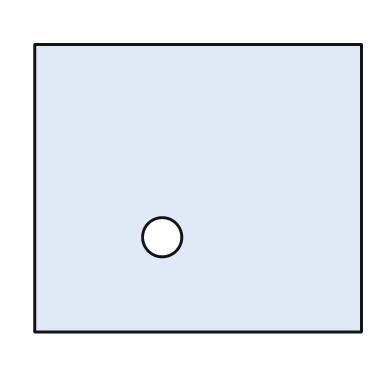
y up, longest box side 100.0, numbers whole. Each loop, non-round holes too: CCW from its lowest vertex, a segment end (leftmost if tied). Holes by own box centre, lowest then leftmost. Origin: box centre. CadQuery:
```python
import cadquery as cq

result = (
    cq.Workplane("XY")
    .moveTo(-50.0, -44.0)
    .lineTo(50.0, -44.0)
    .lineTo(50.0, 44.0)
    .lineTo(-50.0, 44.0)
    .close()
    .moveTo(-11.0, -15.0)
    .circle(6.0)
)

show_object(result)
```